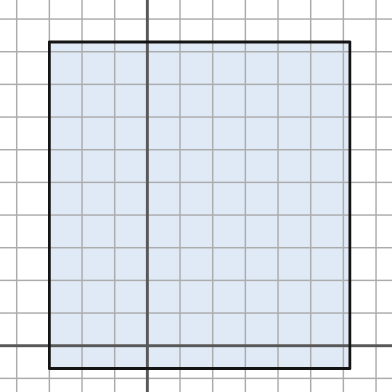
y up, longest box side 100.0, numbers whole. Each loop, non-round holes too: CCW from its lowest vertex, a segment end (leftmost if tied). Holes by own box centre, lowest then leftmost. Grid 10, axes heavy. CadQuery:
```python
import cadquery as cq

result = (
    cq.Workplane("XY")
    .moveTo(-30.0, -7.0)
    .lineTo(62.0, -7.0)
    .lineTo(62.0, 93.0)
    .lineTo(-30.0, 93.0)
    .close()
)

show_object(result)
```